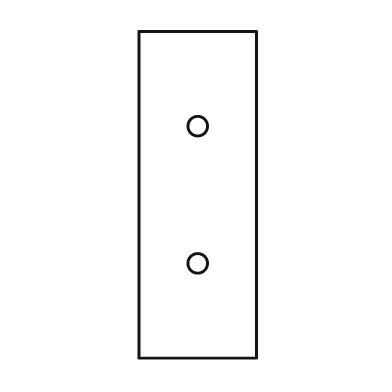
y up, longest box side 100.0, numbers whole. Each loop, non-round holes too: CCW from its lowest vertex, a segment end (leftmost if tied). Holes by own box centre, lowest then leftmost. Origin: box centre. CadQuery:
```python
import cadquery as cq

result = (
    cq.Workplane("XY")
    .moveTo(-18.0, -50.0)
    .lineTo(18.0, -50.0)
    .lineTo(18.0, 50.0)
    .lineTo(-18.0, 50.0)
    .close()
    .moveTo(0.0, -21.0)
    .circle(3.0)
    .moveTo(0.0, 21.0)
    .circle(3.0)
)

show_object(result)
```